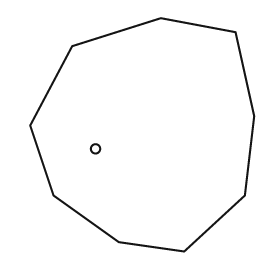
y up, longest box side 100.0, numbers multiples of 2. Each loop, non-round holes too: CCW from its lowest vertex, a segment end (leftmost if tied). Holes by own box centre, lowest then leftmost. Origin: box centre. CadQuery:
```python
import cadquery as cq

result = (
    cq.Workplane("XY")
    .moveTo(18.0, -50.0)
    .lineTo(44.0, -26.0)
    .lineTo(48.0, 8.0)
    .lineTo(40.0, 44.0)
    .lineTo(8.0, 50.0)
    .lineTo(-30.0, 38.0)
    .lineTo(-48.0, 4.0)
    .lineTo(-38.0, -26.0)
    .lineTo(-10.0, -46.0)
    .close()
    .moveTo(-20.0, -6.0)
    .circle(2.0)
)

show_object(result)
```